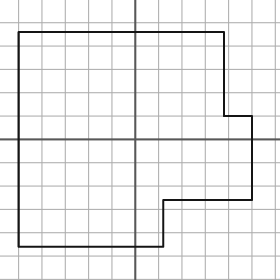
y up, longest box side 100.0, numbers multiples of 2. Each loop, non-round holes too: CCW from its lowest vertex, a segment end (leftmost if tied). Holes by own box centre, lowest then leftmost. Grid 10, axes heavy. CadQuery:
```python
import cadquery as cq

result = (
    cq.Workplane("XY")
    .moveTo(-50.0, -46.0)
    .lineTo(12.0, -46.0)
    .lineTo(12.0, -26.0)
    .lineTo(50.0, -26.0)
    .lineTo(50.0, 10.0)
    .lineTo(38.0, 10.0)
    .lineTo(38.0, 46.0)
    .lineTo(-50.0, 46.0)
    .close()
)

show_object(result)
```